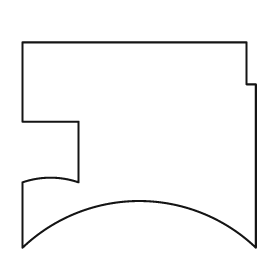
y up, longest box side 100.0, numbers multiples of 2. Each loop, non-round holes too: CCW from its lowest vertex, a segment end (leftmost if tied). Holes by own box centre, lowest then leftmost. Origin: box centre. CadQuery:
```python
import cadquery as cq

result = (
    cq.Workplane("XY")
    .moveTo(-50.0, -44.0)
    .threePointArc((0.0, -24.0), (50.0, -44.0))
    .lineTo(50.0, 26.0)
    .lineTo(46.0, 26.0)
    .lineTo(46.0, 44.0)
    .lineTo(-50.0, 44.0)
    .lineTo(-50.0, 10.0)
    .lineTo(-26.0, 10.0)
    .lineTo(-26.0, -16.0)
    .threePointArc((-38.0, -14.0), (-50.0, -16.0))
    .close()
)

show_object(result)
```